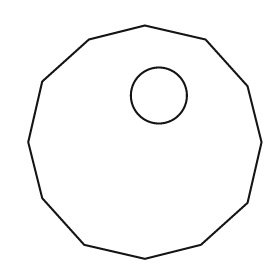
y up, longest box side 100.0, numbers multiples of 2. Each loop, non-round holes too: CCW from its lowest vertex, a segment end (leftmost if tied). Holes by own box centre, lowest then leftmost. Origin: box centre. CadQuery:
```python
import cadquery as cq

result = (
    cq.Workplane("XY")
    .moveTo(0.0, -50.0)
    .lineTo(24.0, -44.0)
    .lineTo(44.0, -26.0)
    .lineTo(50.0, 0.0)
    .lineTo(44.0, 24.0)
    .lineTo(26.0, 44.0)
    .lineTo(0.0, 50.0)
    .lineTo(-24.0, 44.0)
    .lineTo(-44.0, 26.0)
    .lineTo(-50.0, 0.0)
    .lineTo(-44.0, -24.0)
    .lineTo(-26.0, -44.0)
    .close()
    .moveTo(6.0, 20.0)
    .circle(12.0)
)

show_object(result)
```